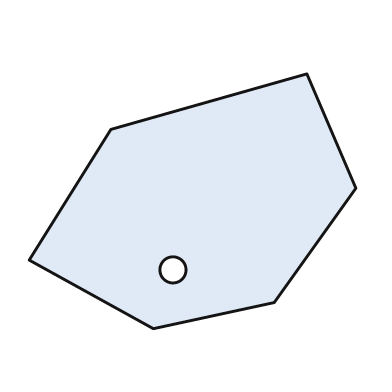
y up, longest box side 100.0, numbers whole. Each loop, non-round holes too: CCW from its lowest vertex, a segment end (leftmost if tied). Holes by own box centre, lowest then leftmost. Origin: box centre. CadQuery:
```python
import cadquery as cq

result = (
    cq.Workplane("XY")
    .moveTo(-12.0, -39.0)
    .lineTo(25.0, -31.0)
    .lineTo(50.0, 4.0)
    .lineTo(35.0, 39.0)
    .lineTo(-25.0, 22.0)
    .lineTo(-50.0, -18.0)
    .close()
    .moveTo(-6.0, -21.0)
    .circle(4.0)
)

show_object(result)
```